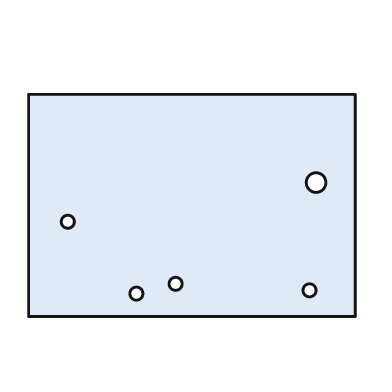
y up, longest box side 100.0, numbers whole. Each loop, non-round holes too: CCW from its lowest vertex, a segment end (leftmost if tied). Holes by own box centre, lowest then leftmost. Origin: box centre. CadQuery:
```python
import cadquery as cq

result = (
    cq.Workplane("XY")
    .moveTo(-50.0, -34.0)
    .lineTo(50.0, -34.0)
    .lineTo(50.0, 34.0)
    .lineTo(-50.0, 34.0)
    .close()
    .moveTo(-17.0, -27.0)
    .circle(2.0)
    .moveTo(36.0, -26.0)
    .circle(2.0)
    .moveTo(-5.0, -24.0)
    .circle(2.0)
    .moveTo(-38.0, -5.0)
    .circle(2.0)
    .moveTo(38.0, 7.0)
    .circle(3.0)
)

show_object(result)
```